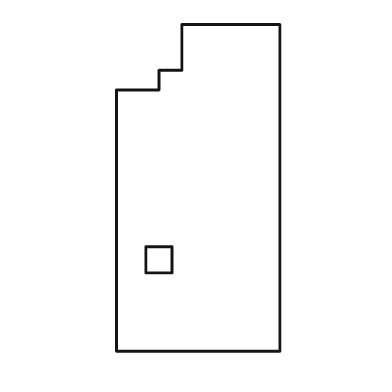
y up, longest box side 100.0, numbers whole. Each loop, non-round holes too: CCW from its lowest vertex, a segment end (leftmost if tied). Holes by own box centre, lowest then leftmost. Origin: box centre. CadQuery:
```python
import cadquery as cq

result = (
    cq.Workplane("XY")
    .moveTo(-25.0, -50.0)
    .lineTo(25.0, -50.0)
    .lineTo(25.0, 50.0)
    .lineTo(-5.0, 50.0)
    .lineTo(-5.0, 36.0)
    .lineTo(-12.0, 36.0)
    .lineTo(-12.0, 30.0)
    .lineTo(-25.0, 30.0)
    .close()
    .moveTo(-16.0, -26.0)
    .lineTo(-8.0, -26.0)
    .lineTo(-8.0, -18.0)
    .lineTo(-16.0, -18.0)
    .close()
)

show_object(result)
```